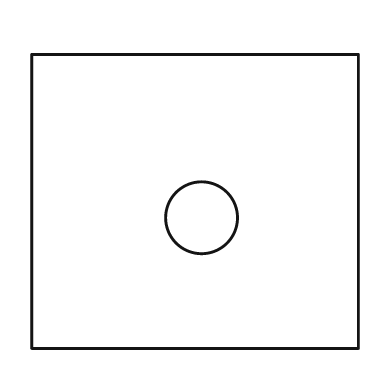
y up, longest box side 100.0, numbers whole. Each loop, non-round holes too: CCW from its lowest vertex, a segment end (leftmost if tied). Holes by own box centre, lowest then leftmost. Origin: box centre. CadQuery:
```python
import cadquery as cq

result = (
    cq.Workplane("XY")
    .moveTo(-50.0, -45.0)
    .lineTo(50.0, -45.0)
    .lineTo(50.0, 45.0)
    .lineTo(-50.0, 45.0)
    .close()
    .moveTo(2.0, -5.0)
    .circle(11.0)
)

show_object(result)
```